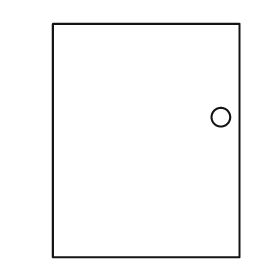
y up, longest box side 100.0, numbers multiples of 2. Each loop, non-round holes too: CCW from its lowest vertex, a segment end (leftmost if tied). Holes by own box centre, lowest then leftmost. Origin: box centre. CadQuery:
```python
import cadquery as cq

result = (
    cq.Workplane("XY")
    .moveTo(-40.0, -50.0)
    .lineTo(40.0, -50.0)
    .lineTo(40.0, 50.0)
    .lineTo(-40.0, 50.0)
    .close()
    .moveTo(32.0, 10.0)
    .circle(4.0)
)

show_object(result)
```